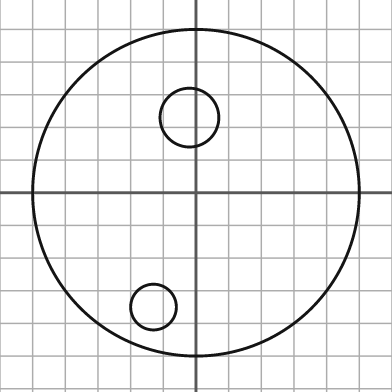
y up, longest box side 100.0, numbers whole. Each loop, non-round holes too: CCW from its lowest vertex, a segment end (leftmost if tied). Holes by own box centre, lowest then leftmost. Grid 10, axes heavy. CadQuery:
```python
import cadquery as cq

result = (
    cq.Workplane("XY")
    .moveTo(0.0, 0.0)
    .circle(50.0)
    .moveTo(-13.0, -35.0)
    .circle(7.0)
    .moveTo(-2.0, 23.0)
    .circle(9.0)
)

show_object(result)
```